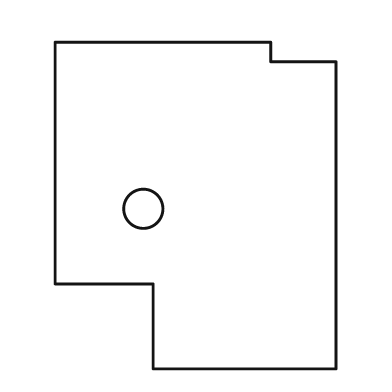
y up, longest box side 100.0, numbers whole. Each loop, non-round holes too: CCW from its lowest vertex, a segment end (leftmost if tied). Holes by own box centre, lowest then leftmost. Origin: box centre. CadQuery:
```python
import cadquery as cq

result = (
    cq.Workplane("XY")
    .moveTo(-13.0, -50.0)
    .lineTo(43.0, -50.0)
    .lineTo(43.0, 44.0)
    .lineTo(23.0, 44.0)
    .lineTo(23.0, 50.0)
    .lineTo(-43.0, 50.0)
    .lineTo(-43.0, -24.0)
    .lineTo(-13.0, -24.0)
    .close()
    .moveTo(-16.0, -1.0)
    .circle(6.0)
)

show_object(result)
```